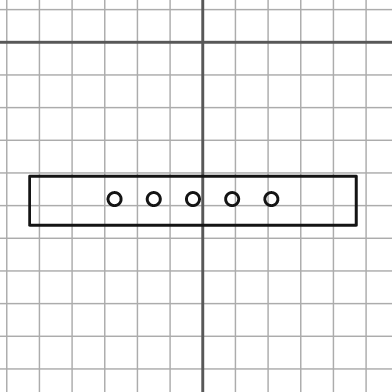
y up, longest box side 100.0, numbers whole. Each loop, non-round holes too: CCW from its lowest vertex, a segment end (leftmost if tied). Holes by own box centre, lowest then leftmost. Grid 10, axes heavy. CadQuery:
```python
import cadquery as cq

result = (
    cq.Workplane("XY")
    .moveTo(-53.0, -56.0)
    .lineTo(47.0, -56.0)
    .lineTo(47.0, -41.0)
    .lineTo(-53.0, -41.0)
    .close()
    .moveTo(-27.0, -48.0)
    .circle(2.0)
    .moveTo(-15.0, -48.0)
    .circle(2.0)
    .moveTo(-3.0, -48.0)
    .circle(2.0)
    .moveTo(9.0, -48.0)
    .circle(2.0)
    .moveTo(21.0, -48.0)
    .circle(2.0)
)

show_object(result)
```